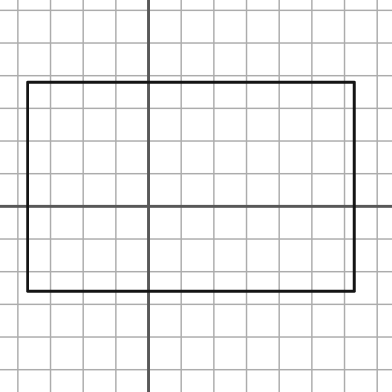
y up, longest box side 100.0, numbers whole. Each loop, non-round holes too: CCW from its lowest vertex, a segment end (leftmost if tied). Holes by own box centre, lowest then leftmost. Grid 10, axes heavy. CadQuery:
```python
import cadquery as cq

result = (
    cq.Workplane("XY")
    .moveTo(-37.0, -26.0)
    .lineTo(63.0, -26.0)
    .lineTo(63.0, 38.0)
    .lineTo(-37.0, 38.0)
    .close()
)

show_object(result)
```